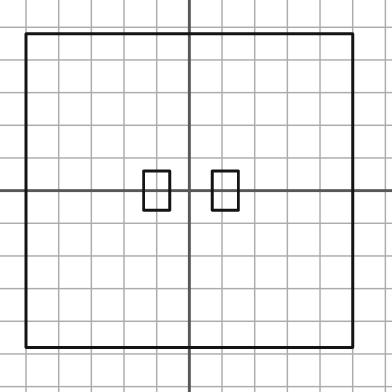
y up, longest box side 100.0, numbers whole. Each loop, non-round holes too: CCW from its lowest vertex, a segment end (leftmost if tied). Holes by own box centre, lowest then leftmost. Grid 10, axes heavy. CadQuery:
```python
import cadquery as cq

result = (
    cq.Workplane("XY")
    .moveTo(-50.0, -48.0)
    .lineTo(50.0, -48.0)
    .lineTo(50.0, 48.0)
    .lineTo(-50.0, 48.0)
    .close()
    .moveTo(-14.0, -6.0)
    .lineTo(-6.0, -6.0)
    .lineTo(-6.0, 6.0)
    .lineTo(-14.0, 6.0)
    .close()
    .moveTo(7.0, -6.0)
    .lineTo(15.0, -6.0)
    .lineTo(15.0, 6.0)
    .lineTo(7.0, 6.0)
    .close()
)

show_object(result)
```